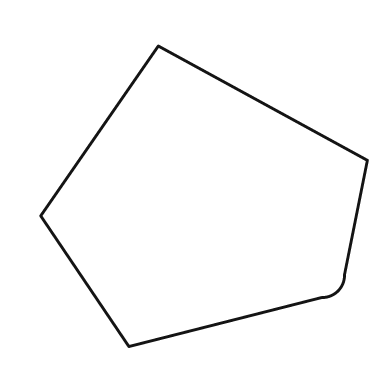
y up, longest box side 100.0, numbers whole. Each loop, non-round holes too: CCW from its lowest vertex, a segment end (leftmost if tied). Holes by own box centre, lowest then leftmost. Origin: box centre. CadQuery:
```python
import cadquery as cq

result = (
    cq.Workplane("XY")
    .moveTo(-23.0, -46.0)
    .lineTo(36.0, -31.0)
    .threePointArc((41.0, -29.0), (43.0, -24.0))
    .lineTo(50.0, 11.0)
    .lineTo(-14.0, 46.0)
    .lineTo(-50.0, -6.0)
    .close()
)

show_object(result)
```